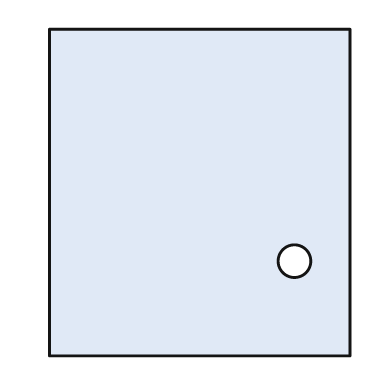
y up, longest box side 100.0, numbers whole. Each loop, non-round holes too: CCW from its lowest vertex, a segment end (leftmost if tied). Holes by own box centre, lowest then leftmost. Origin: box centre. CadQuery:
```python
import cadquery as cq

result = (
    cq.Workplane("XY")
    .moveTo(-46.0, -50.0)
    .lineTo(46.0, -50.0)
    .lineTo(46.0, 50.0)
    .lineTo(-46.0, 50.0)
    .close()
    .moveTo(29.0, -21.0)
    .circle(5.0)
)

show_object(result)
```